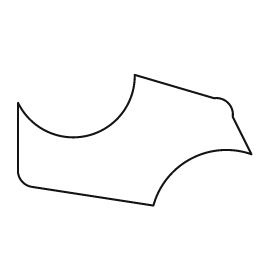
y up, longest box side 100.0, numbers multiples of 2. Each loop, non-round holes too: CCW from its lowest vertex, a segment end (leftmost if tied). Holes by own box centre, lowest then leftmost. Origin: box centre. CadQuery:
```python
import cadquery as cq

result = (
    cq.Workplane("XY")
    .moveTo(8.0, -28.0)
    .threePointArc((24.0, -8.0), (50.0, -6.0))
    .lineTo(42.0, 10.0)
    .threePointArc((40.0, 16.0), (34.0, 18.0))
    .lineTo(0.0, 28.0)
    .threePointArc((-20.0, 2.0), (-50.0, 16.0))
    .lineTo(-50.0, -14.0)
    .threePointArc((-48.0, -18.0), (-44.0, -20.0))
    .close()
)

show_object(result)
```